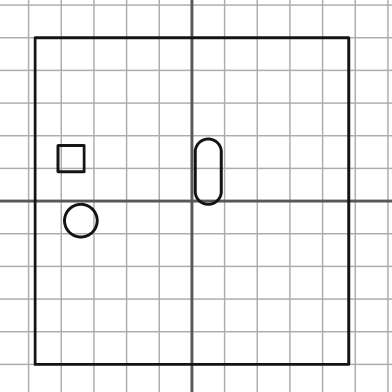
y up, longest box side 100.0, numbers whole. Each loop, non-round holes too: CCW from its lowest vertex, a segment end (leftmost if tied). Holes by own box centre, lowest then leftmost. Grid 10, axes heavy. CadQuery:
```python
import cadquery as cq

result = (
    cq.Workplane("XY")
    .moveTo(-48.0, -50.0)
    .lineTo(48.0, -50.0)
    .lineTo(48.0, 50.0)
    .lineTo(-48.0, 50.0)
    .close()
    .moveTo(-34.0, -6.0)
    .circle(5.0)
    .moveTo(1.0, 3.0)
    .threePointArc((5.0, -1.0), (9.0, 3.0))
    .lineTo(9.0, 15.0)
    .threePointArc((5.0, 19.0), (1.0, 15.0))
    .close()
    .moveTo(-41.0, 9.0)
    .lineTo(-33.0, 9.0)
    .lineTo(-33.0, 17.0)
    .lineTo(-41.0, 17.0)
    .close()
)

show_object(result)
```